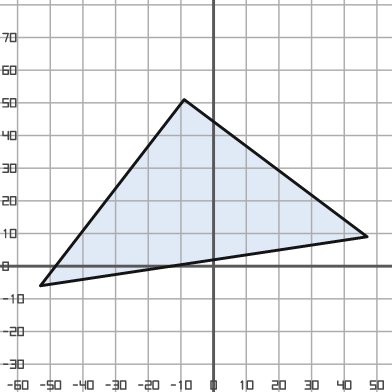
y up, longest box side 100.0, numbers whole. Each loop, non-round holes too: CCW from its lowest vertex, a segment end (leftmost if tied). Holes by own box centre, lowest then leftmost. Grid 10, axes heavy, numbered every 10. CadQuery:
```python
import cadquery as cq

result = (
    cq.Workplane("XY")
    .moveTo(-53.0, -6.0)
    .lineTo(47.0, 9.0)
    .lineTo(-9.0, 51.0)
    .close()
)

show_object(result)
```